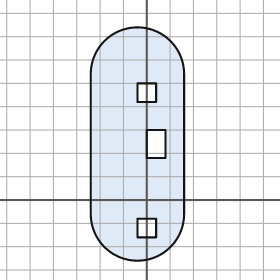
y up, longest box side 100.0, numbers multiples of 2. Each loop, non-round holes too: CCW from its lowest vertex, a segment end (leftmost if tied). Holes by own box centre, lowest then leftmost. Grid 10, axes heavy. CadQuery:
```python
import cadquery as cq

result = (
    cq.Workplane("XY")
    .moveTo(-24.0, -6.0)
    .threePointArc((-4.0, -26.0), (16.0, -6.0))
    .lineTo(16.0, 54.0)
    .threePointArc((-4.0, 74.0), (-24.0, 54.0))
    .close()
    .moveTo(-4.0, -16.0)
    .lineTo(4.0, -16.0)
    .lineTo(4.0, -8.0)
    .lineTo(-4.0, -8.0)
    .close()
    .moveTo(0.0, 18.0)
    .lineTo(8.0, 18.0)
    .lineTo(8.0, 30.0)
    .lineTo(0.0, 30.0)
    .close()
    .moveTo(-4.0, 42.0)
    .lineTo(4.0, 42.0)
    .lineTo(4.0, 50.0)
    .lineTo(-4.0, 50.0)
    .close()
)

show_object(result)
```